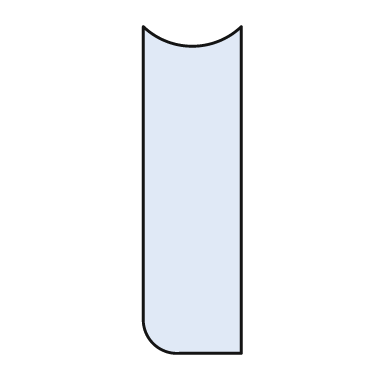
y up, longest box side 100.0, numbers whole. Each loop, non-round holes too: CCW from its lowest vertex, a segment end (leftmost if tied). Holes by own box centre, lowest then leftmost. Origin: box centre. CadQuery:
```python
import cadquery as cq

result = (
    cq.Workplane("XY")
    .moveTo(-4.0, -50.0)
    .lineTo(15.0, -50.0)
    .lineTo(15.0, 50.0)
    .threePointArc((0.0, 44.0), (-15.0, 50.0))
    .lineTo(-15.0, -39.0)
    .threePointArc((-12.0, -47.0), (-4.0, -50.0))
    .close()
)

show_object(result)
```